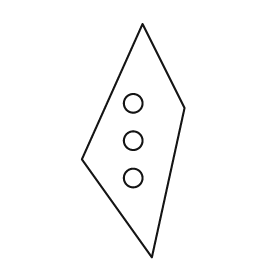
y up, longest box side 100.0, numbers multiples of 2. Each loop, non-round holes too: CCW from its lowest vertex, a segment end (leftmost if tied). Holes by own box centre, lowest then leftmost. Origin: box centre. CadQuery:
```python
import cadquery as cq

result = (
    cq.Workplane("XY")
    .moveTo(8.0, -50.0)
    .lineTo(22.0, 14.0)
    .lineTo(4.0, 50.0)
    .lineTo(-22.0, -8.0)
    .close()
    .moveTo(0.0, -16.0)
    .circle(4.0)
    .moveTo(0.0, 0.0)
    .circle(4.0)
    .moveTo(0.0, 16.0)
    .circle(4.0)
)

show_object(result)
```